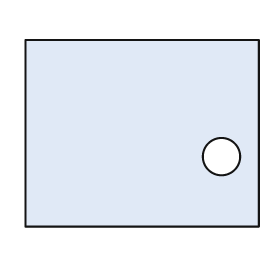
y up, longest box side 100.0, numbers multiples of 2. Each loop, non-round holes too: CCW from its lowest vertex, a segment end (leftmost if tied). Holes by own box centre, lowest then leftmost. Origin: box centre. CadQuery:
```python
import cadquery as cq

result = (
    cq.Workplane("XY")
    .moveTo(-50.0, -40.0)
    .lineTo(50.0, -40.0)
    .lineTo(50.0, 40.0)
    .lineTo(-50.0, 40.0)
    .close()
    .moveTo(34.0, -10.0)
    .circle(8.0)
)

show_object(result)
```